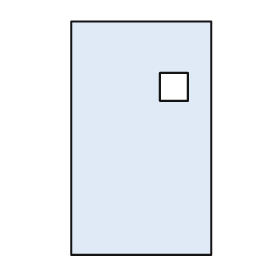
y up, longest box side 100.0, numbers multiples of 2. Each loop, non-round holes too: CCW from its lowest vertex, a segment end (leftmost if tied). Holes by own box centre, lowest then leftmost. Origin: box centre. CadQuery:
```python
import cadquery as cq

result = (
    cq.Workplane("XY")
    .moveTo(-30.0, -50.0)
    .lineTo(30.0, -50.0)
    .lineTo(30.0, 50.0)
    .lineTo(-30.0, 50.0)
    .close()
    .moveTo(8.0, 16.0)
    .lineTo(20.0, 16.0)
    .lineTo(20.0, 28.0)
    .lineTo(8.0, 28.0)
    .close()
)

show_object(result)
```